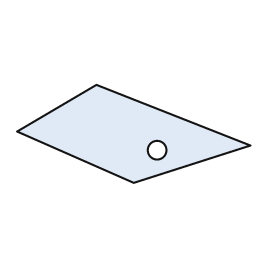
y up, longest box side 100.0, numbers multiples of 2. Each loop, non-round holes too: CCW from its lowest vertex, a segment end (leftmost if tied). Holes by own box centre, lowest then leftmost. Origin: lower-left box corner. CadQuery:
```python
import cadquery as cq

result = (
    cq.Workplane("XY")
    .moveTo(50.0, 0.0)
    .lineTo(100.0, 16.0)
    .lineTo(34.0, 42.0)
    .lineTo(0.0, 22.0)
    .close()
    .moveTo(60.0, 14.0)
    .circle(4.0)
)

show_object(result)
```